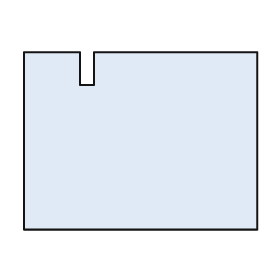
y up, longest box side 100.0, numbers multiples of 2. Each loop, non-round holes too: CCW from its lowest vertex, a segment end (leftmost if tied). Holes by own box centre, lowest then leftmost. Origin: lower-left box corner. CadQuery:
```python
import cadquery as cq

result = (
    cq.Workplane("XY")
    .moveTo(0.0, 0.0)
    .lineTo(100.0, 0.0)
    .lineTo(100.0, 76.0)
    .lineTo(30.0, 76.0)
    .lineTo(30.0, 62.0)
    .lineTo(24.0, 62.0)
    .lineTo(24.0, 76.0)
    .lineTo(0.0, 76.0)
    .close()
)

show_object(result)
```